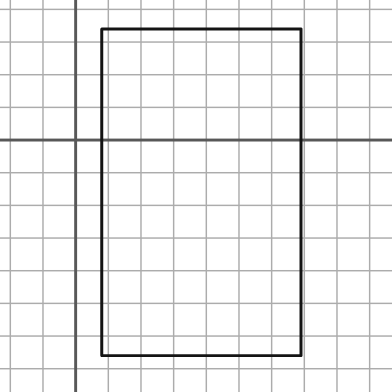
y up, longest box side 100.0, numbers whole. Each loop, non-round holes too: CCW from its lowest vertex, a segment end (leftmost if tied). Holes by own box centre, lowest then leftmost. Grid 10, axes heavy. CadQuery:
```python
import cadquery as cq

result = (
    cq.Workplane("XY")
    .moveTo(8.0, -66.0)
    .lineTo(69.0, -66.0)
    .lineTo(69.0, 34.0)
    .lineTo(8.0, 34.0)
    .close()
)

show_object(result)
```